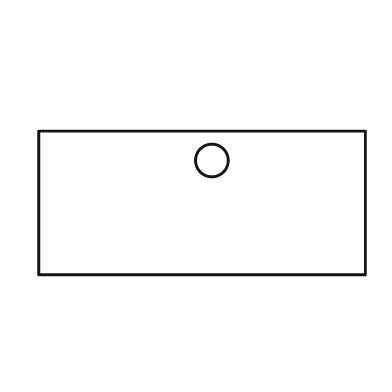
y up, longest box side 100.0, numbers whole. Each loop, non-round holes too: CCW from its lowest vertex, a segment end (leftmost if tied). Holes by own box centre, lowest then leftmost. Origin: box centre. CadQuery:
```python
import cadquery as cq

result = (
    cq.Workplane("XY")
    .moveTo(-50.0, -22.0)
    .lineTo(50.0, -22.0)
    .lineTo(50.0, 22.0)
    .lineTo(-50.0, 22.0)
    .close()
    .moveTo(3.0, 13.0)
    .circle(5.0)
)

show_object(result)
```